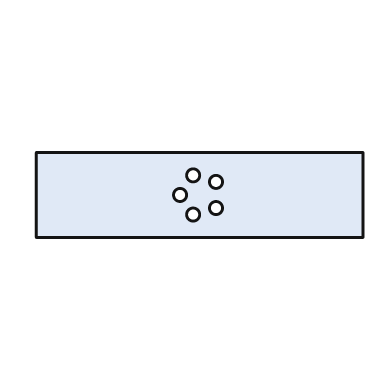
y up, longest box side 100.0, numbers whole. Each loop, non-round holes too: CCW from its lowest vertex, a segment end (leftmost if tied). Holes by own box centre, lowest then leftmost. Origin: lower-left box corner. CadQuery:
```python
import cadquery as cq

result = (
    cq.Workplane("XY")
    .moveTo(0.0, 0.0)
    .lineTo(100.0, 0.0)
    .lineTo(100.0, 26.0)
    .lineTo(0.0, 26.0)
    .close()
    .moveTo(48.0, 7.0)
    .circle(2.0)
    .moveTo(55.0, 9.0)
    .circle(2.0)
    .moveTo(44.0, 13.0)
    .circle(2.0)
    .moveTo(55.0, 17.0)
    .circle(2.0)
    .moveTo(48.0, 19.0)
    .circle(2.0)
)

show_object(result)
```